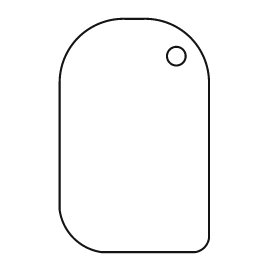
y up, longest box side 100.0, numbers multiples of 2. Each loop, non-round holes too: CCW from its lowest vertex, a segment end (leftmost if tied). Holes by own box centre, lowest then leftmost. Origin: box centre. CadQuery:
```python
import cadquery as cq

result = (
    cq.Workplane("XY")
    .moveTo(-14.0, -50.0)
    .lineTo(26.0, -50.0)
    .threePointArc((30.0, -48.0), (32.0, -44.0))
    .lineTo(32.0, 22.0)
    .threePointArc((24.0, 42.0), (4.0, 50.0))
    .lineTo(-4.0, 50.0)
    .threePointArc((-24.0, 42.0), (-32.0, 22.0))
    .lineTo(-32.0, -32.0)
    .threePointArc((-26.0, -44.0), (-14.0, -50.0))
    .close()
    .moveTo(18.0, 34.0)
    .circle(4.0)
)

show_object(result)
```